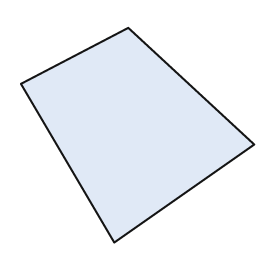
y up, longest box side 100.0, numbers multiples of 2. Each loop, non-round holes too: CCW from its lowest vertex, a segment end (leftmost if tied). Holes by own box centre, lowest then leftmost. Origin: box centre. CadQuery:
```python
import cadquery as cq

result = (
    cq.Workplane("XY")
    .moveTo(-10.0, -46.0)
    .lineTo(50.0, -4.0)
    .lineTo(-4.0, 46.0)
    .lineTo(-50.0, 22.0)
    .close()
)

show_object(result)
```